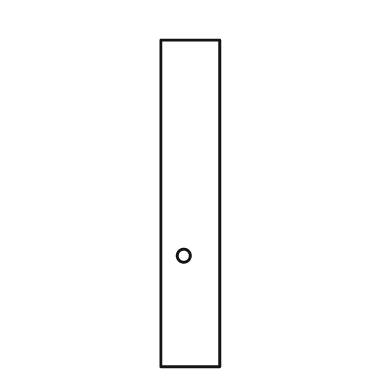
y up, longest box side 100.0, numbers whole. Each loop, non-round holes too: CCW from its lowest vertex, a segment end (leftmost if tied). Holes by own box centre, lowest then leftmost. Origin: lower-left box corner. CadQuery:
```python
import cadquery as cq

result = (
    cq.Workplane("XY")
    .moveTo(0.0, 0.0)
    .lineTo(18.0, 0.0)
    .lineTo(18.0, 100.0)
    .lineTo(0.0, 100.0)
    .close()
    .moveTo(7.0, 34.0)
    .circle(2.0)
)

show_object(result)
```